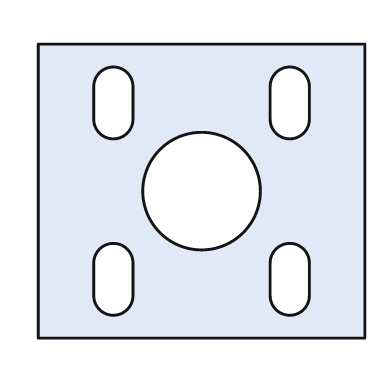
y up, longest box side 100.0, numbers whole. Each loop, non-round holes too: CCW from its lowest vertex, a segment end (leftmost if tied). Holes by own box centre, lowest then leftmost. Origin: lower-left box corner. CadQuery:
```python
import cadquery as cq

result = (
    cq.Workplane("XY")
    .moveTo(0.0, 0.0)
    .lineTo(100.0, 0.0)
    .lineTo(100.0, 90.0)
    .lineTo(0.0, 90.0)
    .close()
    .moveTo(17.0, 13.0)
    .threePointArc((23.0, 7.0), (29.0, 13.0))
    .lineTo(29.0, 23.0)
    .threePointArc((23.0, 29.0), (17.0, 23.0))
    .close()
    .moveTo(71.0, 13.0)
    .threePointArc((77.0, 7.0), (83.0, 13.0))
    .lineTo(83.0, 23.0)
    .threePointArc((77.0, 29.0), (71.0, 23.0))
    .close()
    .moveTo(50.0, 45.0)
    .circle(18.0)
    .moveTo(17.0, 67.0)
    .threePointArc((23.0, 61.0), (29.0, 67.0))
    .lineTo(29.0, 77.0)
    .threePointArc((23.0, 83.0), (17.0, 77.0))
    .close()
    .moveTo(71.0, 67.0)
    .threePointArc((77.0, 61.0), (83.0, 67.0))
    .lineTo(83.0, 77.0)
    .threePointArc((77.0, 83.0), (71.0, 77.0))
    .close()
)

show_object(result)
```